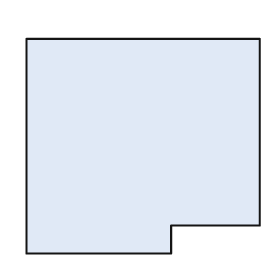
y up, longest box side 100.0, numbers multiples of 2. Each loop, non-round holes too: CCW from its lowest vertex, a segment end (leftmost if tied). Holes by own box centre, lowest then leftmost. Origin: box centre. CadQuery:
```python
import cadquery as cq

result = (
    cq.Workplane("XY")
    .moveTo(-50.0, -46.0)
    .lineTo(12.0, -46.0)
    .lineTo(12.0, -34.0)
    .lineTo(50.0, -34.0)
    .lineTo(50.0, 46.0)
    .lineTo(-50.0, 46.0)
    .close()
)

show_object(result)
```